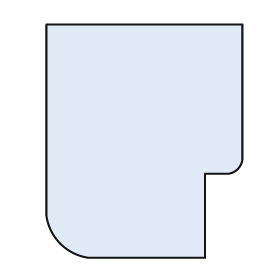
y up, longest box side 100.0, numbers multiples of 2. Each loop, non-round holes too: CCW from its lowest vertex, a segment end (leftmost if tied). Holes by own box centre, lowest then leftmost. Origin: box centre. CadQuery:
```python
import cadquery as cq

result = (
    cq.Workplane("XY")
    .moveTo(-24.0, -50.0)
    .lineTo(26.0, -50.0)
    .lineTo(26.0, -14.0)
    .lineTo(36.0, -14.0)
    .threePointArc((40.0, -12.0), (42.0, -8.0))
    .lineTo(42.0, 50.0)
    .lineTo(-42.0, 50.0)
    .lineTo(-42.0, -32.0)
    .threePointArc((-36.0, -44.0), (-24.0, -50.0))
    .close()
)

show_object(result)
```